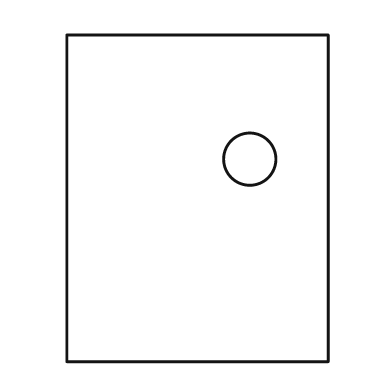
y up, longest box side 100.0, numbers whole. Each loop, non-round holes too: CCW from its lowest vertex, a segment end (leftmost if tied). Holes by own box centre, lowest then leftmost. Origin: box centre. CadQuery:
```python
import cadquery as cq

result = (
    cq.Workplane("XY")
    .moveTo(-40.0, -50.0)
    .lineTo(40.0, -50.0)
    .lineTo(40.0, 50.0)
    .lineTo(-40.0, 50.0)
    .close()
    .moveTo(16.0, 12.0)
    .circle(8.0)
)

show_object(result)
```